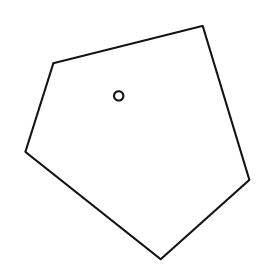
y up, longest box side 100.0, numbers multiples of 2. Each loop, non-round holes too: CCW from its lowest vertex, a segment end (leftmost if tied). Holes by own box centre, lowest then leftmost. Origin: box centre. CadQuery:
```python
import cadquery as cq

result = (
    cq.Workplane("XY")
    .moveTo(10.0, -50.0)
    .lineTo(48.0, -16.0)
    .lineTo(28.0, 50.0)
    .lineTo(-36.0, 34.0)
    .lineTo(-48.0, -4.0)
    .close()
    .moveTo(-8.0, 20.0)
    .circle(2.0)
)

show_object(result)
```